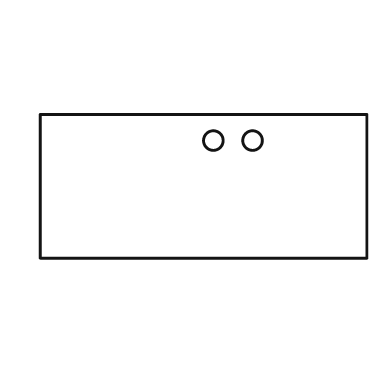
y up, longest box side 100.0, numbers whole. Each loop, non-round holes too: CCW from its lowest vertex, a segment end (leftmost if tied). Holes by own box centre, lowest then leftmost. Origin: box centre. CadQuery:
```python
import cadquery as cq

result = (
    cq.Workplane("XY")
    .moveTo(-50.0, -22.0)
    .lineTo(50.0, -22.0)
    .lineTo(50.0, 22.0)
    .lineTo(-50.0, 22.0)
    .close()
    .moveTo(3.0, 14.0)
    .circle(3.0)
    .moveTo(15.0, 14.0)
    .circle(3.0)
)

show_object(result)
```